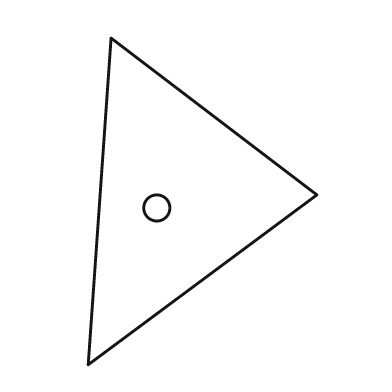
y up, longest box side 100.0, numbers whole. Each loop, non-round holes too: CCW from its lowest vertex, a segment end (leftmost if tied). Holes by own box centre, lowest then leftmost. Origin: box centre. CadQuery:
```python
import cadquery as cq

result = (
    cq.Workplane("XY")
    .moveTo(-35.0, -50.0)
    .lineTo(35.0, 2.0)
    .lineTo(-28.0, 50.0)
    .close()
    .moveTo(-14.0, -2.0)
    .circle(4.0)
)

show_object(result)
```